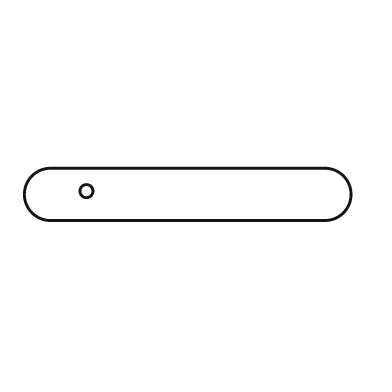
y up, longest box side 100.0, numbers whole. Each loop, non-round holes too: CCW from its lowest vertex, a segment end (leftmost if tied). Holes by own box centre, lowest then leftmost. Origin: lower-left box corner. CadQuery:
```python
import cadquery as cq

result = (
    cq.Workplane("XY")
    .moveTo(8.0, 0.0)
    .lineTo(92.0, 0.0)
    .threePointArc((100.0, 8.0), (92.0, 16.0))
    .lineTo(8.0, 16.0)
    .threePointArc((0.0, 8.0), (8.0, 0.0))
    .close()
    .moveTo(19.0, 9.0)
    .circle(2.0)
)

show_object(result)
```